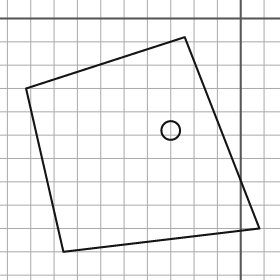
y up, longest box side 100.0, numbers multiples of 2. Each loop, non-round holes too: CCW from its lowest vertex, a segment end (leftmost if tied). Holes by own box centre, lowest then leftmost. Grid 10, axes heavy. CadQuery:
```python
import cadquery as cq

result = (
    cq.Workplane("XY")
    .moveTo(-76.0, -100.0)
    .lineTo(8.0, -90.0)
    .lineTo(-24.0, -8.0)
    .lineTo(-92.0, -30.0)
    .close()
    .moveTo(-30.0, -48.0)
    .circle(4.0)
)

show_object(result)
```